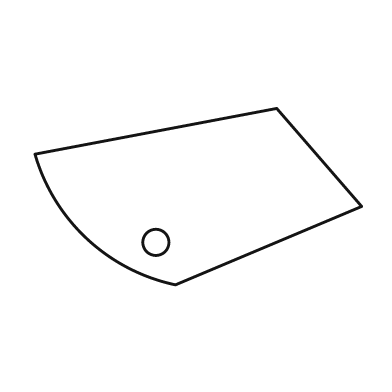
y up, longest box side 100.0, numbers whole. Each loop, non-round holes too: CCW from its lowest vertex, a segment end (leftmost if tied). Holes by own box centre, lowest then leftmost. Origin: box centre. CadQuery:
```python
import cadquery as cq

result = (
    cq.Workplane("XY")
    .moveTo(-7.0, -27.0)
    .lineTo(50.0, -3.0)
    .lineTo(24.0, 27.0)
    .lineTo(-50.0, 13.0)
    .threePointArc((-34.0, -13.0), (-7.0, -27.0))
    .close()
    .moveTo(-13.0, -14.0)
    .circle(4.0)
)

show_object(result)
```